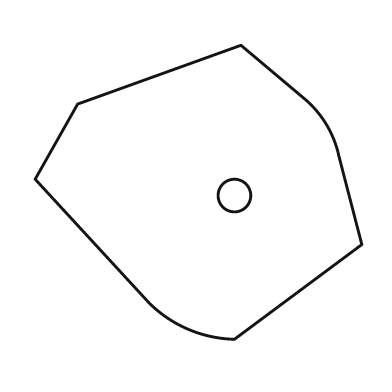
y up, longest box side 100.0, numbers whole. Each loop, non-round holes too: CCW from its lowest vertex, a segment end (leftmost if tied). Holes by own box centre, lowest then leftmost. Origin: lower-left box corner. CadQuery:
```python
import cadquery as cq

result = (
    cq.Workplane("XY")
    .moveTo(61.0, 0.0)
    .lineTo(100.0, 29.0)
    .lineTo(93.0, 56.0)
    .threePointArc((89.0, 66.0), (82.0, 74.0))
    .lineTo(63.0, 90.0)
    .lineTo(13.0, 72.0)
    .lineTo(0.0, 49.0)
    .lineTo(35.0, 11.0)
    .threePointArc((47.0, 3.0), (61.0, 0.0))
    .close()
    .moveTo(61.0, 44.0)
    .circle(5.0)
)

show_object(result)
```